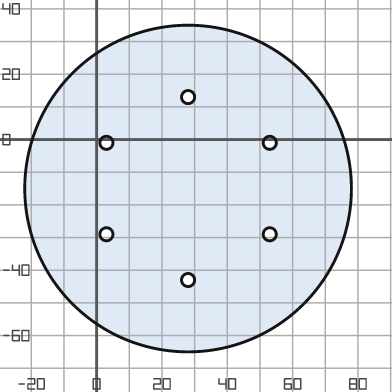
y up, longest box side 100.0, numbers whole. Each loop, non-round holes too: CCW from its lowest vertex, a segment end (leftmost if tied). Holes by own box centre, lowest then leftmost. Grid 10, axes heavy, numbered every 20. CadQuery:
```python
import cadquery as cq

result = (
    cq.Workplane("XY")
    .moveTo(28.0, -15.0)
    .circle(50.0)
    .moveTo(28.0, -43.0)
    .circle(2.0)
    .moveTo(3.0, -29.0)
    .circle(2.0)
    .moveTo(53.0, -29.0)
    .circle(2.0)
    .moveTo(3.0, -1.0)
    .circle(2.0)
    .moveTo(53.0, -1.0)
    .circle(2.0)
    .moveTo(28.0, 13.0)
    .circle(2.0)
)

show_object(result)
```